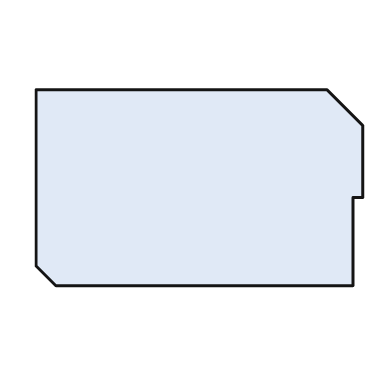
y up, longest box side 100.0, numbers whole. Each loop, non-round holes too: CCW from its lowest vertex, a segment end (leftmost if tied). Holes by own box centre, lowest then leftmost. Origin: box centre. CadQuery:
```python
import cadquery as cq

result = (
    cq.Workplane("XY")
    .moveTo(-44.0, -30.0)
    .lineTo(47.0, -30.0)
    .lineTo(47.0, -3.0)
    .lineTo(50.0, -3.0)
    .lineTo(50.0, 19.0)
    .lineTo(39.0, 30.0)
    .lineTo(-50.0, 30.0)
    .lineTo(-50.0, -24.0)
    .close()
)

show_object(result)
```